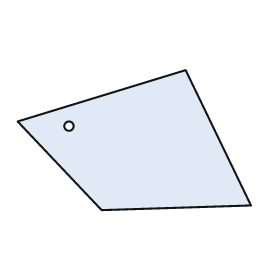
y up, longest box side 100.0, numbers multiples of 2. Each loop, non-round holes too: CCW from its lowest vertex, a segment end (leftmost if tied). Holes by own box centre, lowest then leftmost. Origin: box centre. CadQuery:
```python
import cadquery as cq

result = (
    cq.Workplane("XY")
    .moveTo(-14.0, -30.0)
    .lineTo(50.0, -28.0)
    .lineTo(22.0, 30.0)
    .lineTo(-50.0, 8.0)
    .close()
    .moveTo(-28.0, 6.0)
    .circle(2.0)
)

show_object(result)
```